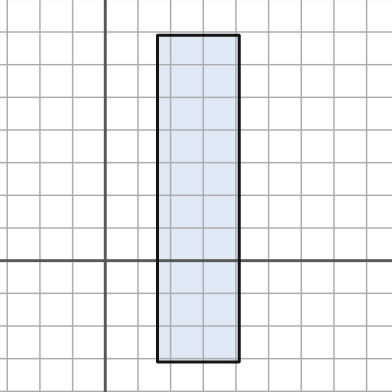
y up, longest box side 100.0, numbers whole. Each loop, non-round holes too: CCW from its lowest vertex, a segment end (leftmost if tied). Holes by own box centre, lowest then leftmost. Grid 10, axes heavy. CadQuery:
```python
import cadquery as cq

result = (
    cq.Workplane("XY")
    .moveTo(16.0, -31.0)
    .lineTo(41.0, -31.0)
    .lineTo(41.0, 69.0)
    .lineTo(16.0, 69.0)
    .close()
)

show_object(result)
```